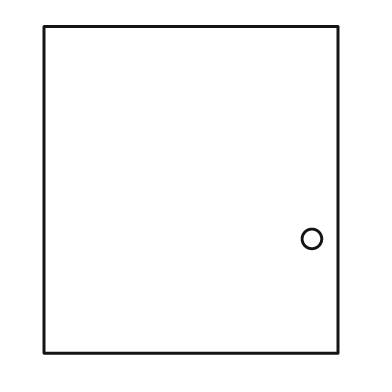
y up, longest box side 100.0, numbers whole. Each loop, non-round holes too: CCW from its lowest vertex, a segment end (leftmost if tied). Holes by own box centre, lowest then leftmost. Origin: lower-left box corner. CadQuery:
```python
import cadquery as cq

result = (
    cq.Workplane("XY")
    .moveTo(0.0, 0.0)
    .lineTo(90.0, 0.0)
    .lineTo(90.0, 100.0)
    .lineTo(0.0, 100.0)
    .close()
    .moveTo(82.0, 35.0)
    .circle(3.0)
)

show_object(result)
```